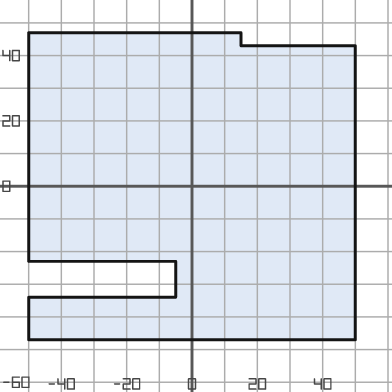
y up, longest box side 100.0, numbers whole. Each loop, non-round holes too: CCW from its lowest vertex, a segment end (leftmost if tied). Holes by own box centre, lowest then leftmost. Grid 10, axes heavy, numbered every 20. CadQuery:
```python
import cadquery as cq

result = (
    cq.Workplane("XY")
    .moveTo(-50.0, -47.0)
    .lineTo(50.0, -47.0)
    .lineTo(50.0, 43.0)
    .lineTo(15.0, 43.0)
    .lineTo(15.0, 47.0)
    .lineTo(-50.0, 47.0)
    .lineTo(-50.0, -23.0)
    .lineTo(-5.0, -23.0)
    .lineTo(-5.0, -34.0)
    .lineTo(-50.0, -34.0)
    .close()
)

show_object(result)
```